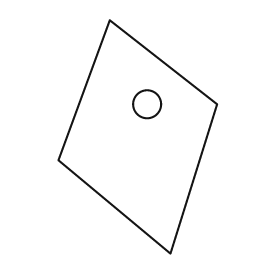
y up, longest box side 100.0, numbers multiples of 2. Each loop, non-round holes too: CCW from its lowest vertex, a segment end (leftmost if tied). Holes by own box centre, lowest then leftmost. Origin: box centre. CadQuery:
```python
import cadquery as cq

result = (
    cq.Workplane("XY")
    .moveTo(14.0, -50.0)
    .lineTo(34.0, 14.0)
    .lineTo(-12.0, 50.0)
    .lineTo(-34.0, -10.0)
    .close()
    .moveTo(4.0, 14.0)
    .circle(6.0)
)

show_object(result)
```